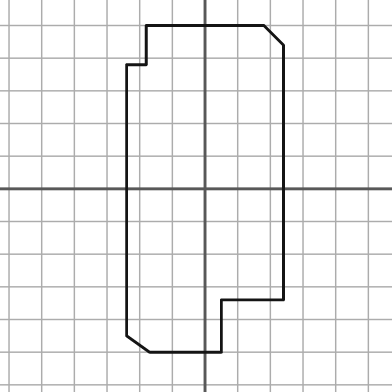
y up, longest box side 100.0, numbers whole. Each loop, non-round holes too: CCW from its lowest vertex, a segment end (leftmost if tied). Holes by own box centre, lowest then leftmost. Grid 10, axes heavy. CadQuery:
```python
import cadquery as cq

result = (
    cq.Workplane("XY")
    .moveTo(-17.0, -50.0)
    .lineTo(5.0, -50.0)
    .lineTo(5.0, -34.0)
    .lineTo(24.0, -34.0)
    .lineTo(24.0, 44.0)
    .lineTo(18.0, 50.0)
    .lineTo(-18.0, 50.0)
    .lineTo(-18.0, 38.0)
    .lineTo(-24.0, 38.0)
    .lineTo(-24.0, -45.0)
    .close()
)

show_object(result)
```